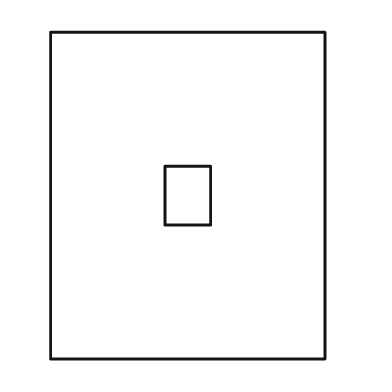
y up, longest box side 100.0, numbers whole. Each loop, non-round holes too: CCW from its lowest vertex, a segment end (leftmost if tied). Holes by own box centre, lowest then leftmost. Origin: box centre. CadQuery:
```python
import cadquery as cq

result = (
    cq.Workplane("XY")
    .moveTo(-42.0, -50.0)
    .lineTo(42.0, -50.0)
    .lineTo(42.0, 50.0)
    .lineTo(-42.0, 50.0)
    .close()
    .moveTo(-7.0, -9.0)
    .lineTo(7.0, -9.0)
    .lineTo(7.0, 9.0)
    .lineTo(-7.0, 9.0)
    .close()
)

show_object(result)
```